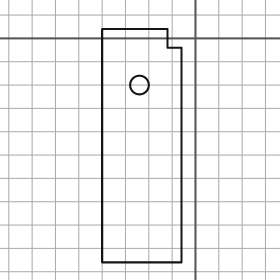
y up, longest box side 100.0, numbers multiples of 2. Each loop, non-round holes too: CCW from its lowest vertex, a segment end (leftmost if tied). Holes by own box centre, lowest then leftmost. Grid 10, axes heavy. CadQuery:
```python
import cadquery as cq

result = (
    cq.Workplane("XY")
    .moveTo(-40.0, -96.0)
    .lineTo(-6.0, -96.0)
    .lineTo(-6.0, -4.0)
    .lineTo(-12.0, -4.0)
    .lineTo(-12.0, 4.0)
    .lineTo(-40.0, 4.0)
    .close()
    .moveTo(-24.0, -20.0)
    .circle(4.0)
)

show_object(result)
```